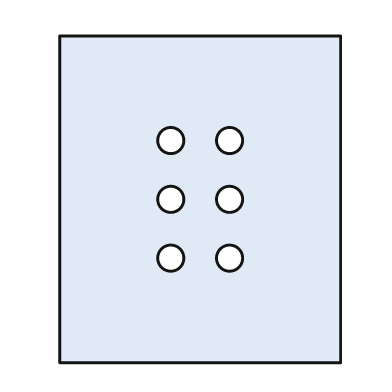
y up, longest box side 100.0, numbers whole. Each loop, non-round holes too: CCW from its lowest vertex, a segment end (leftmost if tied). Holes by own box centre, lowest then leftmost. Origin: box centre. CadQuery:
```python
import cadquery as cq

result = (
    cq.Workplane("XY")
    .moveTo(-43.0, -50.0)
    .lineTo(43.0, -50.0)
    .lineTo(43.0, 50.0)
    .lineTo(-43.0, 50.0)
    .close()
    .moveTo(-9.0, -18.0)
    .circle(4.0)
    .moveTo(9.0, -18.0)
    .circle(4.0)
    .moveTo(-9.0, 0.0)
    .circle(4.0)
    .moveTo(9.0, 0.0)
    .circle(4.0)
    .moveTo(-9.0, 18.0)
    .circle(4.0)
    .moveTo(9.0, 18.0)
    .circle(4.0)
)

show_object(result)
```